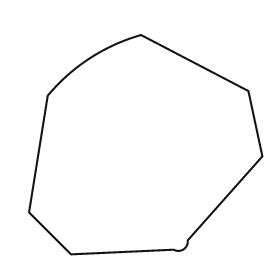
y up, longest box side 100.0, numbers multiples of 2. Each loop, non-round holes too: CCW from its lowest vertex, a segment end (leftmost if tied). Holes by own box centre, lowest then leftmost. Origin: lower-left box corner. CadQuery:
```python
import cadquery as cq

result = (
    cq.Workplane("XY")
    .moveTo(18.0, 0.0)
    .lineTo(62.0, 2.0)
    .threePointArc((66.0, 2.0), (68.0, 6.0))
    .lineTo(100.0, 42.0)
    .lineTo(94.0, 70.0)
    .lineTo(48.0, 94.0)
    .threePointArc((26.0, 84.0), (8.0, 68.0))
    .lineTo(0.0, 18.0)
    .close()
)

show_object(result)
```